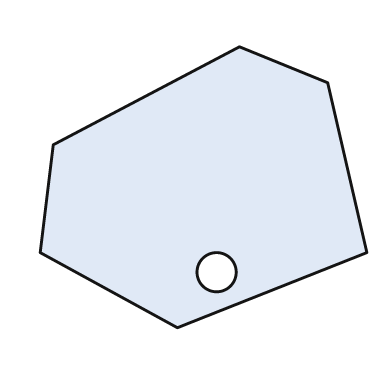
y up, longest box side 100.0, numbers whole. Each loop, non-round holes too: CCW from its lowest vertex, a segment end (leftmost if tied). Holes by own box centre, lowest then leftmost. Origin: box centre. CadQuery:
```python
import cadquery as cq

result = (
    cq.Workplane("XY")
    .moveTo(-8.0, -43.0)
    .lineTo(50.0, -20.0)
    .lineTo(38.0, 32.0)
    .lineTo(11.0, 43.0)
    .lineTo(-46.0, 13.0)
    .lineTo(-50.0, -20.0)
    .close()
    .moveTo(4.0, -26.0)
    .circle(6.0)
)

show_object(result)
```